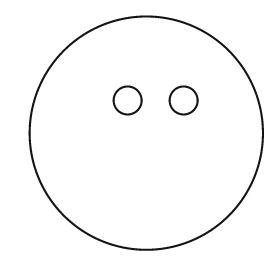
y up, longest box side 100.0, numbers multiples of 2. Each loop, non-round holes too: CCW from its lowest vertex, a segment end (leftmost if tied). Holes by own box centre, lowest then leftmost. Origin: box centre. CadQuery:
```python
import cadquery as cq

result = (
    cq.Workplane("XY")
    .moveTo(0.0, 0.0)
    .circle(50.0)
    .moveTo(-8.0, 14.0)
    .circle(6.0)
    .moveTo(16.0, 14.0)
    .circle(6.0)
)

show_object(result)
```